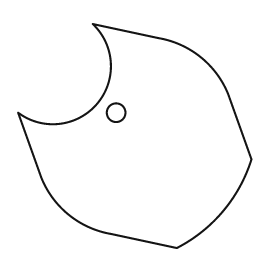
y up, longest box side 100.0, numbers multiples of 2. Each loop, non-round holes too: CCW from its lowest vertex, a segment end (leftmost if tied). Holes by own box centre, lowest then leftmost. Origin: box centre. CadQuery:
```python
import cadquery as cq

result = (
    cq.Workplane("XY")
    .moveTo(18.0, -48.0)
    .threePointArc((38.0, -32.0), (50.0, -10.0))
    .lineTo(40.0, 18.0)
    .threePointArc((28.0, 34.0), (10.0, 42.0))
    .lineTo(-18.0, 48.0)
    .threePointArc((-16.0, 14.0), (-50.0, 10.0))
    .lineTo(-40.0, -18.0)
    .threePointArc((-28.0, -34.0), (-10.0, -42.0))
    .close()
    .moveTo(-8.0, 10.0)
    .circle(4.0)
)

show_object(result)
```